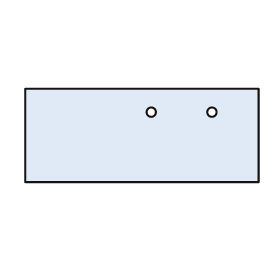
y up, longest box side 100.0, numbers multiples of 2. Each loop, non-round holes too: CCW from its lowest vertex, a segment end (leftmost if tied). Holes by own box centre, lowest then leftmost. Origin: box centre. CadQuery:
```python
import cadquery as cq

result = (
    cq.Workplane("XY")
    .moveTo(-50.0, -20.0)
    .lineTo(50.0, -20.0)
    .lineTo(50.0, 20.0)
    .lineTo(-50.0, 20.0)
    .close()
    .moveTo(4.0, 10.0)
    .circle(2.0)
    .moveTo(30.0, 10.0)
    .circle(2.0)
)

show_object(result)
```